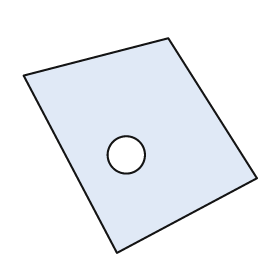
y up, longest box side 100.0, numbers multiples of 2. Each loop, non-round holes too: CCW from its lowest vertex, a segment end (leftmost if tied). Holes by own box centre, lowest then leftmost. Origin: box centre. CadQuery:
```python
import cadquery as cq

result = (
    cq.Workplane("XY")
    .moveTo(-10.0, -46.0)
    .lineTo(50.0, -14.0)
    .lineTo(12.0, 46.0)
    .lineTo(-50.0, 30.0)
    .close()
    .moveTo(-6.0, -4.0)
    .circle(8.0)
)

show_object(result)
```